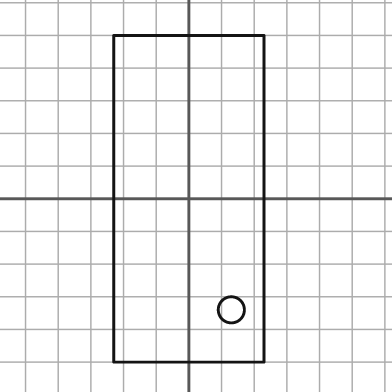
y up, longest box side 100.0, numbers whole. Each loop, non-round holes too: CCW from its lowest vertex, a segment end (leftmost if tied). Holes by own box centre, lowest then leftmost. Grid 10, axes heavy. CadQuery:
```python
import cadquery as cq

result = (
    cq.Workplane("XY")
    .moveTo(-23.0, -50.0)
    .lineTo(23.0, -50.0)
    .lineTo(23.0, 50.0)
    .lineTo(-23.0, 50.0)
    .close()
    .moveTo(13.0, -34.0)
    .circle(4.0)
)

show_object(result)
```